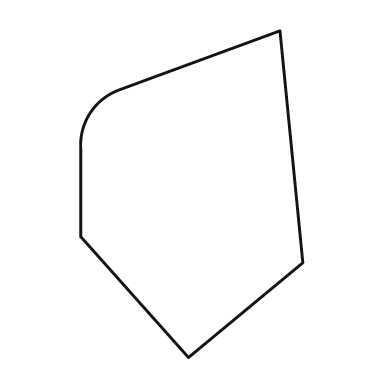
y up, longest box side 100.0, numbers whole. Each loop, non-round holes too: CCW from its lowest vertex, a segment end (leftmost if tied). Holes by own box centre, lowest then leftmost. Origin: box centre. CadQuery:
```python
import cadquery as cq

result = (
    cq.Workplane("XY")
    .moveTo(-1.0, -50.0)
    .lineTo(34.0, -21.0)
    .lineTo(27.0, 50.0)
    .lineTo(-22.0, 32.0)
    .threePointArc((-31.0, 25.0), (-34.0, 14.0))
    .lineTo(-34.0, -13.0)
    .close()
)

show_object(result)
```